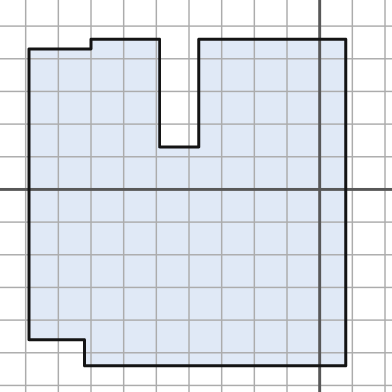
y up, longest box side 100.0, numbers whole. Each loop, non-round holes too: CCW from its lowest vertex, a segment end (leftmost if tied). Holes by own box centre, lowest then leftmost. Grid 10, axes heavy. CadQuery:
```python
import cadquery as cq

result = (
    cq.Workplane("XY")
    .moveTo(-72.0, -54.0)
    .lineTo(8.0, -54.0)
    .lineTo(8.0, 46.0)
    .lineTo(-37.0, 46.0)
    .lineTo(-37.0, 13.0)
    .lineTo(-49.0, 13.0)
    .lineTo(-49.0, 46.0)
    .lineTo(-70.0, 46.0)
    .lineTo(-70.0, 43.0)
    .lineTo(-89.0, 43.0)
    .lineTo(-89.0, -46.0)
    .lineTo(-72.0, -46.0)
    .close()
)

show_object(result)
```